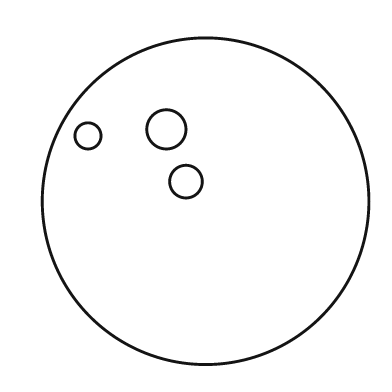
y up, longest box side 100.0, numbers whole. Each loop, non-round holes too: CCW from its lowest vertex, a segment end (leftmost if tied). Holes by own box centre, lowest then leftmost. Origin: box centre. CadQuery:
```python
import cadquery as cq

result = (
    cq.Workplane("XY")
    .moveTo(0.0, 0.0)
    .circle(50.0)
    .moveTo(-6.0, 6.0)
    .circle(5.0)
    .moveTo(-36.0, 20.0)
    .circle(4.0)
    .moveTo(-12.0, 22.0)
    .circle(6.0)
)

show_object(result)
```